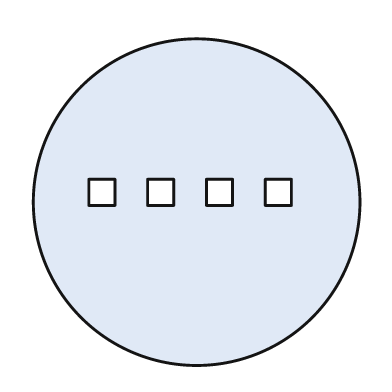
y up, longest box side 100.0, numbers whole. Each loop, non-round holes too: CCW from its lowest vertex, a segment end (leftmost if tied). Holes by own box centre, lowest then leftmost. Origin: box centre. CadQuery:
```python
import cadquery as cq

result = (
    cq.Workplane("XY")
    .moveTo(0.0, 0.0)
    .circle(50.0)
    .moveTo(-33.0, -1.0)
    .lineTo(-25.0, -1.0)
    .lineTo(-25.0, 7.0)
    .lineTo(-33.0, 7.0)
    .close()
    .moveTo(-15.0, -1.0)
    .lineTo(-7.0, -1.0)
    .lineTo(-7.0, 7.0)
    .lineTo(-15.0, 7.0)
    .close()
    .moveTo(3.0, -1.0)
    .lineTo(11.0, -1.0)
    .lineTo(11.0, 7.0)
    .lineTo(3.0, 7.0)
    .close()
    .moveTo(21.0, -1.0)
    .lineTo(29.0, -1.0)
    .lineTo(29.0, 7.0)
    .lineTo(21.0, 7.0)
    .close()
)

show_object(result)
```